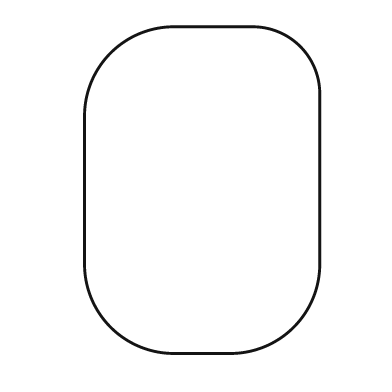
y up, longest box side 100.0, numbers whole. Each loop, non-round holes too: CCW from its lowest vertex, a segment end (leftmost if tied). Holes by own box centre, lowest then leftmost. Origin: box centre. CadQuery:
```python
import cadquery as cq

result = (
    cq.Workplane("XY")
    .moveTo(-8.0, -50.0)
    .lineTo(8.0, -50.0)
    .threePointArc((28.0, -42.0), (36.0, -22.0))
    .lineTo(36.0, 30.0)
    .threePointArc((30.0, 44.0), (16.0, 50.0))
    .lineTo(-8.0, 50.0)
    .threePointArc((-28.0, 42.0), (-36.0, 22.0))
    .lineTo(-36.0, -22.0)
    .threePointArc((-28.0, -42.0), (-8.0, -50.0))
    .close()
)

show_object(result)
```